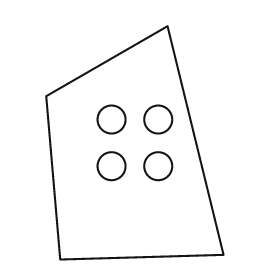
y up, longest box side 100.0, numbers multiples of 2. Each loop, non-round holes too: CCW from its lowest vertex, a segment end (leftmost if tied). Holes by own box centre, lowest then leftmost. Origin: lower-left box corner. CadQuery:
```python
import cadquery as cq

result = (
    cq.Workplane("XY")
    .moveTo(6.0, 0.0)
    .lineTo(76.0, 2.0)
    .lineTo(52.0, 100.0)
    .lineTo(0.0, 70.0)
    .close()
    .moveTo(28.0, 40.0)
    .circle(6.0)
    .moveTo(48.0, 40.0)
    .circle(6.0)
    .moveTo(28.0, 60.0)
    .circle(6.0)
    .moveTo(48.0, 60.0)
    .circle(6.0)
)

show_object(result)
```